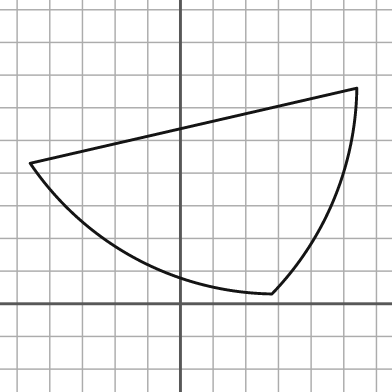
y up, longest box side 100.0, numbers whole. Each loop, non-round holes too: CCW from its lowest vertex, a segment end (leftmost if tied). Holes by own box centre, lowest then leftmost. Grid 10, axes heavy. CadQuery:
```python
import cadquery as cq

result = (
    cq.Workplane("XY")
    .moveTo(28.0, 3.0)
    .threePointArc((47.0, 32.0), (54.0, 66.0))
    .lineTo(-46.0, 43.0)
    .threePointArc((-14.0, 14.0), (28.0, 3.0))
    .close()
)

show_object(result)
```